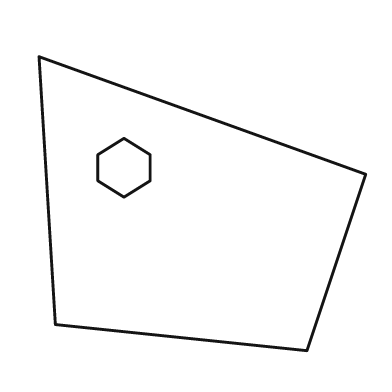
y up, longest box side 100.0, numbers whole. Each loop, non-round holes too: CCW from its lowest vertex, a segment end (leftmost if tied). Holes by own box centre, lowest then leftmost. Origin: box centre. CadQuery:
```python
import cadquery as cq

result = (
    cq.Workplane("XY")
    .moveTo(32.0, -45.0)
    .lineTo(50.0, 9.0)
    .lineTo(-50.0, 45.0)
    .lineTo(-45.0, -37.0)
    .close()
    .moveTo(-24.0, 2.0)
    .lineTo(-16.0, 7.0)
    .lineTo(-16.0, 15.0)
    .lineTo(-24.0, 20.0)
    .lineTo(-32.0, 15.0)
    .lineTo(-32.0, 7.0)
    .close()
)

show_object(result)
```